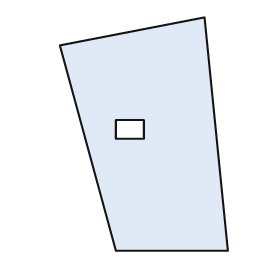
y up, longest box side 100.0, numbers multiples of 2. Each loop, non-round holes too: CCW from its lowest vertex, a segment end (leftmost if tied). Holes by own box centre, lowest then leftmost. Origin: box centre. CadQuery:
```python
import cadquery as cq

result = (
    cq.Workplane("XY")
    .moveTo(-12.0, -50.0)
    .lineTo(36.0, -50.0)
    .lineTo(26.0, 50.0)
    .lineTo(-36.0, 38.0)
    .close()
    .moveTo(-12.0, -2.0)
    .lineTo(0.0, -2.0)
    .lineTo(0.0, 6.0)
    .lineTo(-12.0, 6.0)
    .close()
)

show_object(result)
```